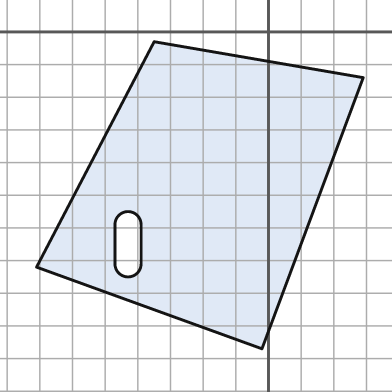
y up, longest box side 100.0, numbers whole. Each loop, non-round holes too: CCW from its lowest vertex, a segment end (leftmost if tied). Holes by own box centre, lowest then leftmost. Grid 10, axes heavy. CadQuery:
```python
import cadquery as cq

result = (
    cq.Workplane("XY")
    .moveTo(-2.0, -97.0)
    .lineTo(29.0, -14.0)
    .lineTo(-35.0, -3.0)
    .lineTo(-71.0, -72.0)
    .close()
    .moveTo(-47.0, -71.0)
    .threePointArc((-43.0, -75.0), (-39.0, -71.0))
    .lineTo(-39.0, -59.0)
    .threePointArc((-43.0, -55.0), (-47.0, -59.0))
    .close()
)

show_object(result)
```